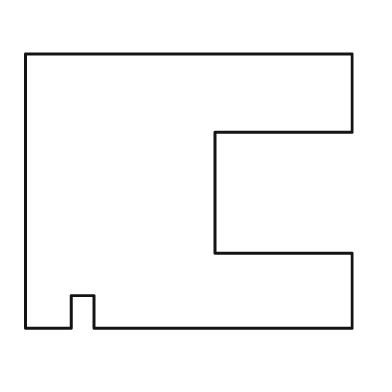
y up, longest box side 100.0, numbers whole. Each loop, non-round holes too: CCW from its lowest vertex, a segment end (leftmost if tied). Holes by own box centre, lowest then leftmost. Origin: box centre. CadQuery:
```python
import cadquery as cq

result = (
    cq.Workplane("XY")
    .moveTo(-50.0, -42.0)
    .lineTo(-36.0, -42.0)
    .lineTo(-36.0, -32.0)
    .lineTo(-29.0, -32.0)
    .lineTo(-29.0, -42.0)
    .lineTo(50.0, -42.0)
    .lineTo(50.0, -19.0)
    .lineTo(8.0, -19.0)
    .lineTo(8.0, 18.0)
    .lineTo(50.0, 18.0)
    .lineTo(50.0, 42.0)
    .lineTo(-50.0, 42.0)
    .close()
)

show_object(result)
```